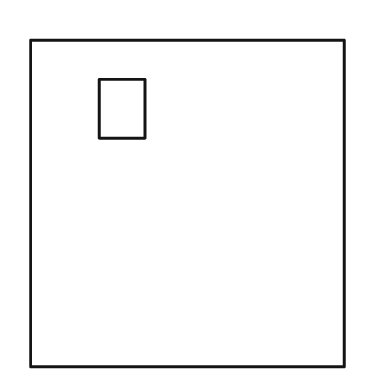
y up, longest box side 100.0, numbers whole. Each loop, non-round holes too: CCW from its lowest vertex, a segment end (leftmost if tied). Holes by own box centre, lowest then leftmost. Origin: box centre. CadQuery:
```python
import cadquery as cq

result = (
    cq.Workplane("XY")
    .moveTo(-48.0, -50.0)
    .lineTo(48.0, -50.0)
    .lineTo(48.0, 50.0)
    .lineTo(-48.0, 50.0)
    .close()
    .moveTo(-27.0, 20.0)
    .lineTo(-13.0, 20.0)
    .lineTo(-13.0, 38.0)
    .lineTo(-27.0, 38.0)
    .close()
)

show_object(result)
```